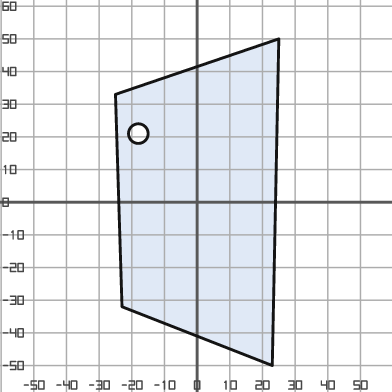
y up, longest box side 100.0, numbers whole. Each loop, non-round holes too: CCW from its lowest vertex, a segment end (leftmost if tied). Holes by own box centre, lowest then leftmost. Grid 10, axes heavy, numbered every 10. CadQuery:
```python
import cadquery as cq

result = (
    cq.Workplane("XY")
    .moveTo(23.0, -50.0)
    .lineTo(25.0, 50.0)
    .lineTo(-25.0, 33.0)
    .lineTo(-23.0, -32.0)
    .close()
    .moveTo(-18.0, 21.0)
    .circle(3.0)
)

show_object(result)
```